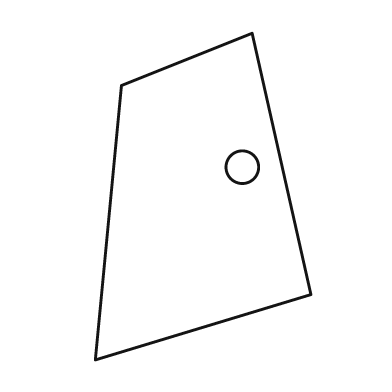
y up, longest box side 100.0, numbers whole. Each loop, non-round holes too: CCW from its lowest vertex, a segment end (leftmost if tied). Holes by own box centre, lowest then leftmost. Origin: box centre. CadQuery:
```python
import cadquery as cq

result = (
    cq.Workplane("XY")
    .moveTo(-33.0, -50.0)
    .lineTo(33.0, -30.0)
    .lineTo(15.0, 50.0)
    .lineTo(-25.0, 34.0)
    .close()
    .moveTo(12.0, 9.0)
    .circle(5.0)
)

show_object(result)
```